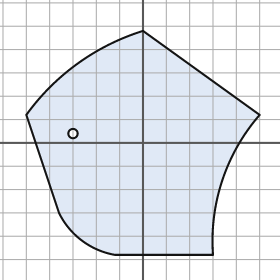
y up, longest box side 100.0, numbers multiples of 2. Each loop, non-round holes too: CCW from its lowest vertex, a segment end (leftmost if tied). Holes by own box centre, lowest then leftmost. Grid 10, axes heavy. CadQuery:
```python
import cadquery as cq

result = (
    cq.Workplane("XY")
    .moveTo(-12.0, -48.0)
    .lineTo(30.0, -48.0)
    .threePointArc((34.0, -16.0), (50.0, 12.0))
    .lineTo(0.0, 48.0)
    .threePointArc((-28.0, 34.0), (-50.0, 12.0))
    .lineTo(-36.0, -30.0)
    .threePointArc((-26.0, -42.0), (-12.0, -48.0))
    .close()
    .moveTo(-30.0, 4.0)
    .circle(2.0)
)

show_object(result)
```